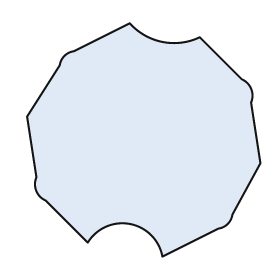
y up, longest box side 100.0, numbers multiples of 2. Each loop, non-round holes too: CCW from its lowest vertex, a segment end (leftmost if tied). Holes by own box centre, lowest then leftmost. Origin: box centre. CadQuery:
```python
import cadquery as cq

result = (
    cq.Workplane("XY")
    .moveTo(8.0, -50.0)
    .lineTo(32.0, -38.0)
    .threePointArc((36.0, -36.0), (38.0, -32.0))
    .lineTo(50.0, -10.0)
    .lineTo(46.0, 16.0)
    .threePointArc((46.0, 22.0), (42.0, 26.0))
    .lineTo(24.0, 44.0)
    .threePointArc((8.0, 42.0), (-6.0, 50.0))
    .lineTo(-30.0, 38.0)
    .threePointArc((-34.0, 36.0), (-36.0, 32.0))
    .lineTo(-50.0, 10.0)
    .lineTo(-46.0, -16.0)
    .threePointArc((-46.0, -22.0), (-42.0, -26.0))
    .lineTo(-24.0, -44.0)
    .threePointArc((-6.0, -36.0), (8.0, -50.0))
    .close()
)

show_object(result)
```